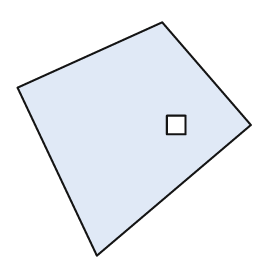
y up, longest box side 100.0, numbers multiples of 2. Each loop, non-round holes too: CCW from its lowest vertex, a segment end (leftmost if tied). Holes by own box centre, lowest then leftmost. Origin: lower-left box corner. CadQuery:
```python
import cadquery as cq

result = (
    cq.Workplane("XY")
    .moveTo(34.0, 0.0)
    .lineTo(100.0, 56.0)
    .lineTo(62.0, 100.0)
    .lineTo(0.0, 72.0)
    .close()
    .moveTo(64.0, 52.0)
    .lineTo(72.0, 52.0)
    .lineTo(72.0, 60.0)
    .lineTo(64.0, 60.0)
    .close()
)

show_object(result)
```